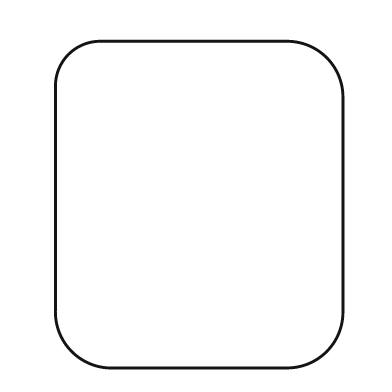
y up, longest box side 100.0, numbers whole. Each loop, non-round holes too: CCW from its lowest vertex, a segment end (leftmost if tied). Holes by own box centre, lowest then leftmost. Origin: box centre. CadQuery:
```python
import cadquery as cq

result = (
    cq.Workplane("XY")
    .moveTo(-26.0, -50.0)
    .lineTo(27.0, -50.0)
    .threePointArc((39.0, -45.0), (44.0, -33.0))
    .lineTo(44.0, 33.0)
    .threePointArc((39.0, 45.0), (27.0, 50.0))
    .lineTo(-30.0, 50.0)
    .threePointArc((-40.0, 46.0), (-44.0, 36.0))
    .lineTo(-44.0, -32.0)
    .threePointArc((-39.0, -45.0), (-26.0, -50.0))
    .close()
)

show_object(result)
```